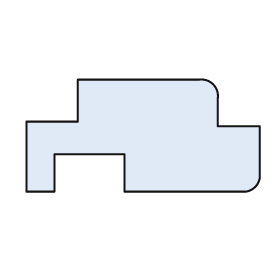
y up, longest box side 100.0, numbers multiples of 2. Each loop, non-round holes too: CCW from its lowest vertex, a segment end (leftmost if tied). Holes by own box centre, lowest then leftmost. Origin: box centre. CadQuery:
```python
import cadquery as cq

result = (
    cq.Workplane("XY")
    .moveTo(-50.0, -24.0)
    .lineTo(-38.0, -24.0)
    .lineTo(-38.0, -8.0)
    .lineTo(-8.0, -8.0)
    .lineTo(-8.0, -24.0)
    .lineTo(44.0, -24.0)
    .threePointArc((48.0, -22.0), (50.0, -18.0))
    .lineTo(50.0, 4.0)
    .lineTo(32.0, 4.0)
    .lineTo(32.0, 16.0)
    .threePointArc((30.0, 22.0), (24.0, 24.0))
    .lineTo(-28.0, 24.0)
    .lineTo(-28.0, 6.0)
    .lineTo(-50.0, 6.0)
    .close()
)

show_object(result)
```